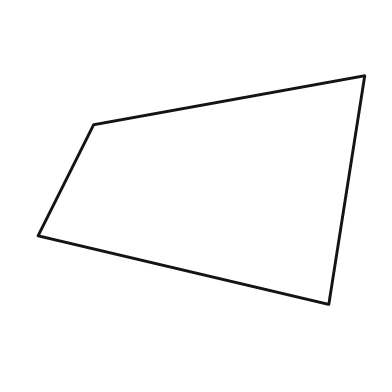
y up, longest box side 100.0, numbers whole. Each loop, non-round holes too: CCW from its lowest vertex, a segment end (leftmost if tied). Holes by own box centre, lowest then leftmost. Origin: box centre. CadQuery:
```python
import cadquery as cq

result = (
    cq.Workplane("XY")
    .moveTo(39.0, -35.0)
    .lineTo(50.0, 35.0)
    .lineTo(-33.0, 20.0)
    .lineTo(-50.0, -14.0)
    .close()
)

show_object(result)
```